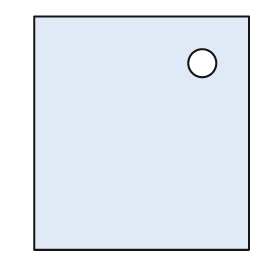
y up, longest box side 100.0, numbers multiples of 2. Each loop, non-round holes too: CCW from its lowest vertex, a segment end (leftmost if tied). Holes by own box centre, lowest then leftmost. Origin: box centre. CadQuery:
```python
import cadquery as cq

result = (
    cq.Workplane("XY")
    .moveTo(-46.0, -50.0)
    .lineTo(46.0, -50.0)
    .lineTo(46.0, 50.0)
    .lineTo(-46.0, 50.0)
    .close()
    .moveTo(26.0, 30.0)
    .circle(6.0)
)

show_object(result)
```